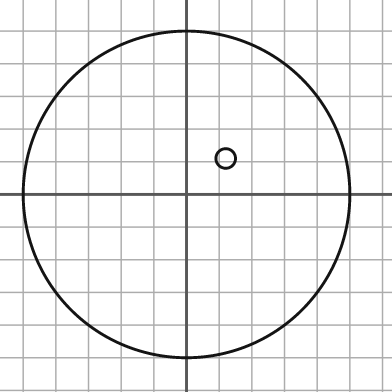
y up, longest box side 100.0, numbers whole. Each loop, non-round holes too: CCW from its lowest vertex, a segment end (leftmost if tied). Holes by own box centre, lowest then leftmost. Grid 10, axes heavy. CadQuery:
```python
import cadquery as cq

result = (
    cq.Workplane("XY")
    .moveTo(0.0, 0.0)
    .circle(50.0)
    .moveTo(12.0, 11.0)
    .circle(3.0)
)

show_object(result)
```